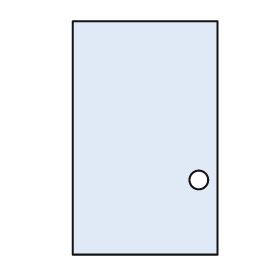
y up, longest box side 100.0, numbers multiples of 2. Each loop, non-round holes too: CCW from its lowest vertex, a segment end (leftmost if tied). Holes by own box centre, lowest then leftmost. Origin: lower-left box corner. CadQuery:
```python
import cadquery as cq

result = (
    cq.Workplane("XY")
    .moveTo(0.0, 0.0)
    .lineTo(62.0, 0.0)
    .lineTo(62.0, 100.0)
    .lineTo(0.0, 100.0)
    .close()
    .moveTo(54.0, 32.0)
    .circle(4.0)
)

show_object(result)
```